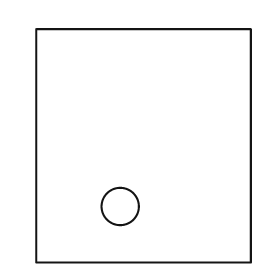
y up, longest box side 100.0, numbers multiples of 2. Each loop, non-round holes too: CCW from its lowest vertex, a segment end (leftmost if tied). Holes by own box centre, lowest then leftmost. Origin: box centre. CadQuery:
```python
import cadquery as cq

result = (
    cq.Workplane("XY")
    .moveTo(-46.0, -50.0)
    .lineTo(46.0, -50.0)
    .lineTo(46.0, 50.0)
    .lineTo(-46.0, 50.0)
    .close()
    .moveTo(-10.0, -26.0)
    .circle(8.0)
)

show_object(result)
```